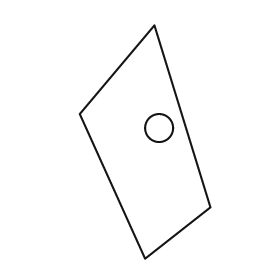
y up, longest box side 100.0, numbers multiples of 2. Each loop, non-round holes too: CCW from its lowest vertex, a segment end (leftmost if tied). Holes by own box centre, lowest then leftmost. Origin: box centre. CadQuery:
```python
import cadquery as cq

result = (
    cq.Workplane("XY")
    .moveTo(0.0, -50.0)
    .lineTo(28.0, -28.0)
    .lineTo(4.0, 50.0)
    .lineTo(-28.0, 12.0)
    .close()
    .moveTo(6.0, 6.0)
    .circle(6.0)
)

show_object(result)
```